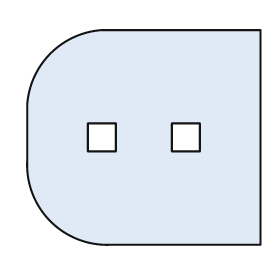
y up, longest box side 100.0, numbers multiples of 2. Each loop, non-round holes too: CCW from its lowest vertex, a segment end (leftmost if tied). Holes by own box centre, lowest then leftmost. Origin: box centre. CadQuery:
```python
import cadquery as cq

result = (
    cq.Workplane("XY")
    .moveTo(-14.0, -46.0)
    .lineTo(50.0, -46.0)
    .lineTo(50.0, 46.0)
    .lineTo(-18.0, 46.0)
    .threePointArc((-40.0, 36.0), (-50.0, 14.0))
    .lineTo(-50.0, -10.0)
    .threePointArc((-40.0, -36.0), (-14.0, -46.0))
    .close()
    .moveTo(-24.0, -6.0)
    .lineTo(-12.0, -6.0)
    .lineTo(-12.0, 6.0)
    .lineTo(-24.0, 6.0)
    .close()
    .moveTo(12.0, -6.0)
    .lineTo(24.0, -6.0)
    .lineTo(24.0, 6.0)
    .lineTo(12.0, 6.0)
    .close()
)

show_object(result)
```